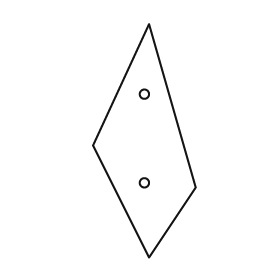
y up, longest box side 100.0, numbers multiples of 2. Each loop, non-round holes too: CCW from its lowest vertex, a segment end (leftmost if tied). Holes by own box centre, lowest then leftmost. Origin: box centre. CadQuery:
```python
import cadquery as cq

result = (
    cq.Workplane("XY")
    .moveTo(2.0, -50.0)
    .lineTo(22.0, -20.0)
    .lineTo(2.0, 50.0)
    .lineTo(-22.0, -2.0)
    .close()
    .moveTo(0.0, -18.0)
    .circle(2.0)
    .moveTo(0.0, 20.0)
    .circle(2.0)
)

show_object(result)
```